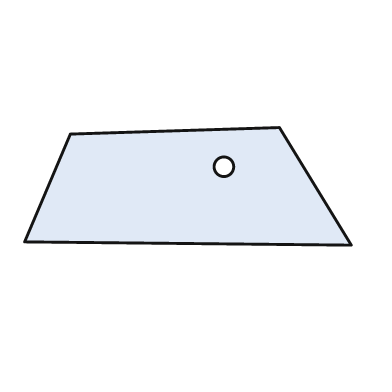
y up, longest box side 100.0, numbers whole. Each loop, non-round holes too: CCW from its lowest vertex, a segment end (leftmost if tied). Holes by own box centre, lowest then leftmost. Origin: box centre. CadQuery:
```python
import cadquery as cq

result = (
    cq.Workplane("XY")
    .moveTo(50.0, -18.0)
    .lineTo(28.0, 18.0)
    .lineTo(-36.0, 16.0)
    .lineTo(-50.0, -17.0)
    .close()
    .moveTo(11.0, 6.0)
    .circle(3.0)
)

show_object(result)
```